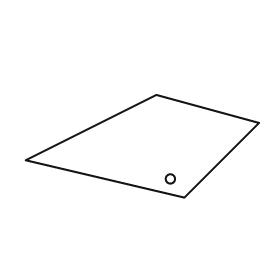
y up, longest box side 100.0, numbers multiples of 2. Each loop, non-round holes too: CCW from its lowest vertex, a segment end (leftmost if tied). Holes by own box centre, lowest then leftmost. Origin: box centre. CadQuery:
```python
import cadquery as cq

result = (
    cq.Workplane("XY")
    .moveTo(18.0, -22.0)
    .lineTo(50.0, 10.0)
    .lineTo(6.0, 22.0)
    .lineTo(-50.0, -6.0)
    .close()
    .moveTo(12.0, -14.0)
    .circle(2.0)
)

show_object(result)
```